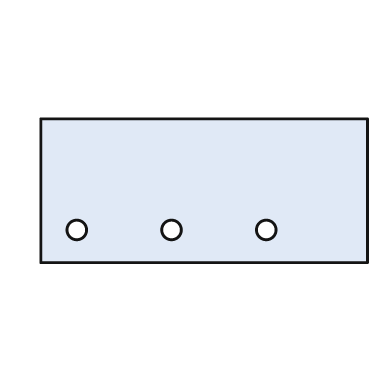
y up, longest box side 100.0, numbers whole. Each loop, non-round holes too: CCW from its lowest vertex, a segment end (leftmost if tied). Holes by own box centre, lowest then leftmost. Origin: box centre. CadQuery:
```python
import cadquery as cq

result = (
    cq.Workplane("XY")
    .moveTo(-50.0, -22.0)
    .lineTo(50.0, -22.0)
    .lineTo(50.0, 22.0)
    .lineTo(-50.0, 22.0)
    .close()
    .moveTo(-39.0, -12.0)
    .circle(3.0)
    .moveTo(-10.0, -12.0)
    .circle(3.0)
    .moveTo(19.0, -12.0)
    .circle(3.0)
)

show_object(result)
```